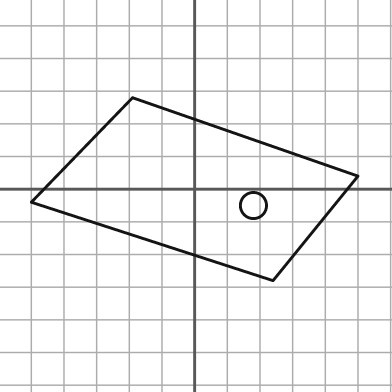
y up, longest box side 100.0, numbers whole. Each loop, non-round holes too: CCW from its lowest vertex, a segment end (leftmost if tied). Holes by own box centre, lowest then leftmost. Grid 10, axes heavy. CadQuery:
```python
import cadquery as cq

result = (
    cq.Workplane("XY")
    .moveTo(24.0, -28.0)
    .lineTo(50.0, 4.0)
    .lineTo(-19.0, 28.0)
    .lineTo(-50.0, -4.0)
    .close()
    .moveTo(18.0, -5.0)
    .circle(4.0)
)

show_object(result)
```